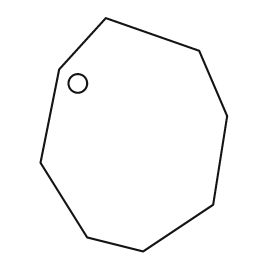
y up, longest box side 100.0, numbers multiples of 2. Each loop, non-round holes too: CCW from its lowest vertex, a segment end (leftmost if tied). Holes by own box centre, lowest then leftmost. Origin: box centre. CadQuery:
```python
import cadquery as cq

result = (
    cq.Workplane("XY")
    .moveTo(4.0, -50.0)
    .lineTo(34.0, -30.0)
    .lineTo(40.0, 8.0)
    .lineTo(28.0, 36.0)
    .lineTo(-12.0, 50.0)
    .lineTo(-32.0, 28.0)
    .lineTo(-40.0, -12.0)
    .lineTo(-20.0, -44.0)
    .close()
    .moveTo(-24.0, 22.0)
    .circle(4.0)
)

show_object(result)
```